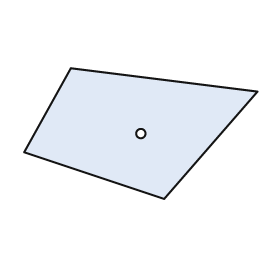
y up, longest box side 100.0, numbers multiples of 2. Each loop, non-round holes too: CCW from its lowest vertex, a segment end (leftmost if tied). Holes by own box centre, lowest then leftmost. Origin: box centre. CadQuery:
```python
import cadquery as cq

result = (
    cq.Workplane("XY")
    .moveTo(10.0, -28.0)
    .lineTo(50.0, 18.0)
    .lineTo(-30.0, 28.0)
    .lineTo(-50.0, -8.0)
    .close()
    .moveTo(0.0, 0.0)
    .circle(2.0)
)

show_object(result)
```